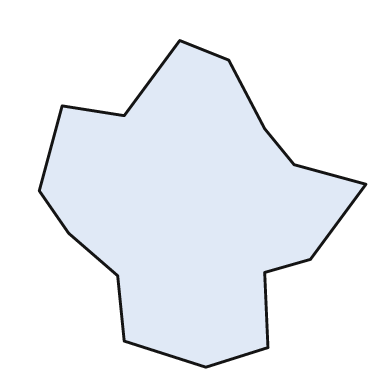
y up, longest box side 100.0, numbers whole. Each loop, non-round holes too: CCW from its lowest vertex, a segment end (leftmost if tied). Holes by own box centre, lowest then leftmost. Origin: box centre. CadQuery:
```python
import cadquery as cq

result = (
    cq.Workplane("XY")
    .moveTo(1.0, -50.0)
    .lineTo(20.0, -44.0)
    .lineTo(19.0, -21.0)
    .lineTo(33.0, -17.0)
    .lineTo(50.0, 6.0)
    .lineTo(28.0, 12.0)
    .lineTo(19.0, 23.0)
    .lineTo(8.0, 44.0)
    .lineTo(-7.0, 50.0)
    .lineTo(-24.0, 27.0)
    .lineTo(-43.0, 30.0)
    .lineTo(-50.0, 4.0)
    .lineTo(-41.0, -9.0)
    .lineTo(-26.0, -22.0)
    .lineTo(-24.0, -42.0)
    .close()
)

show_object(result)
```